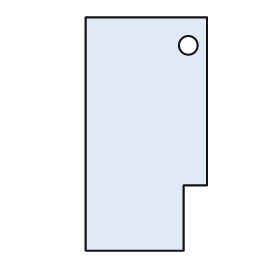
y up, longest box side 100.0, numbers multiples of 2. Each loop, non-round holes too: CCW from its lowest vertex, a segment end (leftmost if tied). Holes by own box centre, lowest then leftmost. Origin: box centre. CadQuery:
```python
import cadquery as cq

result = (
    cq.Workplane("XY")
    .moveTo(-26.0, -50.0)
    .lineTo(16.0, -50.0)
    .lineTo(16.0, -22.0)
    .lineTo(26.0, -22.0)
    .lineTo(26.0, 50.0)
    .lineTo(-26.0, 50.0)
    .close()
    .moveTo(18.0, 38.0)
    .circle(4.0)
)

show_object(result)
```